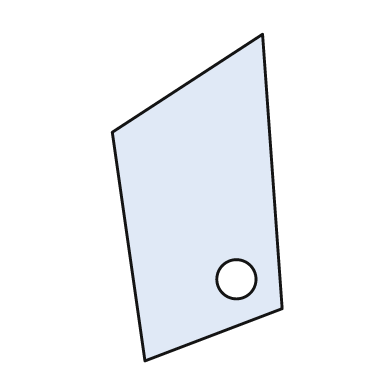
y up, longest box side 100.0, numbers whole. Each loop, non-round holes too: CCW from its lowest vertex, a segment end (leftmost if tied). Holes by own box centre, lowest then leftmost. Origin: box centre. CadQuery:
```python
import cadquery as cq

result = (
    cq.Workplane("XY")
    .moveTo(-16.0, -50.0)
    .lineTo(26.0, -34.0)
    .lineTo(20.0, 50.0)
    .lineTo(-26.0, 20.0)
    .close()
    .moveTo(12.0, -25.0)
    .circle(6.0)
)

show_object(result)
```